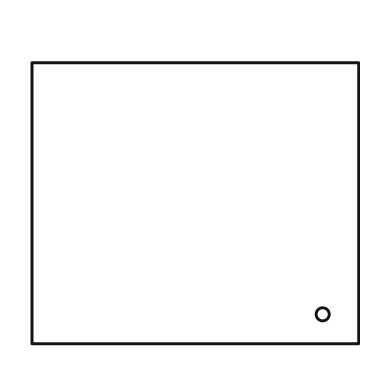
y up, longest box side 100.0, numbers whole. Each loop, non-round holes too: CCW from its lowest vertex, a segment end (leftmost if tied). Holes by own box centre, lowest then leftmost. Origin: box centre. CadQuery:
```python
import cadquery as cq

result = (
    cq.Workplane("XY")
    .moveTo(-50.0, -43.0)
    .lineTo(50.0, -43.0)
    .lineTo(50.0, 43.0)
    .lineTo(-50.0, 43.0)
    .close()
    .moveTo(39.0, -34.0)
    .circle(2.0)
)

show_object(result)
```